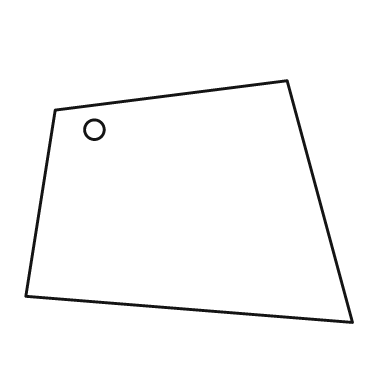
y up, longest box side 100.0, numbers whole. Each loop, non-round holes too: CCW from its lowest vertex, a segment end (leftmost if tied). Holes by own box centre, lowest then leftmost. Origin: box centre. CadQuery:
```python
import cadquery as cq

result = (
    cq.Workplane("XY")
    .moveTo(50.0, -37.0)
    .lineTo(30.0, 37.0)
    .lineTo(-41.0, 28.0)
    .lineTo(-50.0, -29.0)
    .close()
    .moveTo(-29.0, 22.0)
    .circle(3.0)
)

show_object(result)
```